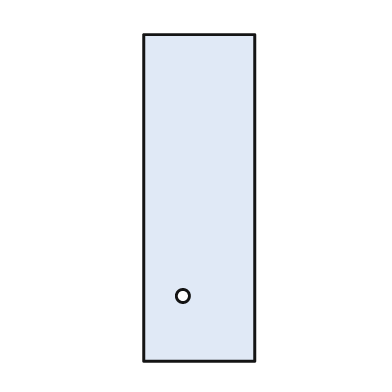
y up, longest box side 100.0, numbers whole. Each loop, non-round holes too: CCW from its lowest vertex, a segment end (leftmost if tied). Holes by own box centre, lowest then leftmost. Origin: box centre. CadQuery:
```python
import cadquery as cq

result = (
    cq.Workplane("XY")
    .moveTo(-17.0, -50.0)
    .lineTo(17.0, -50.0)
    .lineTo(17.0, 50.0)
    .lineTo(-17.0, 50.0)
    .close()
    .moveTo(-5.0, -30.0)
    .circle(2.0)
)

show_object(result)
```